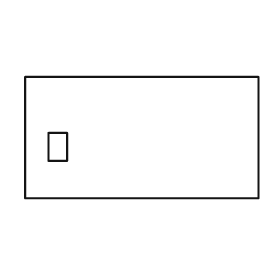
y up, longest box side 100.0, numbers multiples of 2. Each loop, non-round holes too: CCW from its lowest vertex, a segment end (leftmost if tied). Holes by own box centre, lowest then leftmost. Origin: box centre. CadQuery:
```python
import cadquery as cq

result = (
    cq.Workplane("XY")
    .moveTo(-50.0, -26.0)
    .lineTo(50.0, -26.0)
    .lineTo(50.0, 26.0)
    .lineTo(-50.0, 26.0)
    .close()
    .moveTo(-40.0, -10.0)
    .lineTo(-32.0, -10.0)
    .lineTo(-32.0, 2.0)
    .lineTo(-40.0, 2.0)
    .close()
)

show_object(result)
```